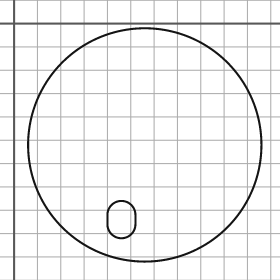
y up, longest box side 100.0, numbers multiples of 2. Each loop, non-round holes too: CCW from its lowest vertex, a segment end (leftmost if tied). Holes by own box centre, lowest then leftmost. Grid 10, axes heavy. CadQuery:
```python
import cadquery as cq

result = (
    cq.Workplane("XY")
    .moveTo(56.0, -52.0)
    .circle(50.0)
    .moveTo(40.0, -86.0)
    .threePointArc((46.0, -92.0), (52.0, -86.0))
    .lineTo(52.0, -82.0)
    .threePointArc((46.0, -76.0), (40.0, -82.0))
    .close()
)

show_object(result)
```